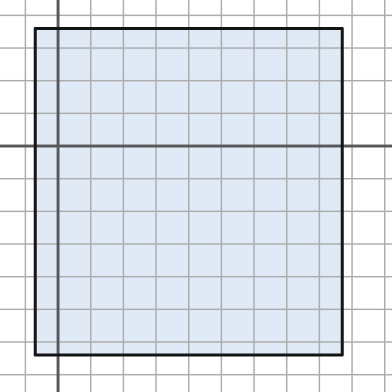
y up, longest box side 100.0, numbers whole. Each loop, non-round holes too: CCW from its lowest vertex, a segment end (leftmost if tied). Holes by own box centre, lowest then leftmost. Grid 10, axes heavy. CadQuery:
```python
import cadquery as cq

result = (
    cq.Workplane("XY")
    .moveTo(-7.0, -64.0)
    .lineTo(87.0, -64.0)
    .lineTo(87.0, 36.0)
    .lineTo(-7.0, 36.0)
    .close()
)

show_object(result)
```